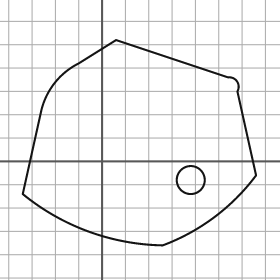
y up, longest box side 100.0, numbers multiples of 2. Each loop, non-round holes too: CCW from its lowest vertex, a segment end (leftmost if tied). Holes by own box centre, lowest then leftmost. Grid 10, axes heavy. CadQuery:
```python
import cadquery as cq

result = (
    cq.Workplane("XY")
    .moveTo(26.0, -36.0)
    .threePointArc((48.0, -24.0), (66.0, -6.0))
    .lineTo(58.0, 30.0)
    .threePointArc((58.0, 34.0), (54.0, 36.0))
    .lineTo(6.0, 52.0)
    .lineTo(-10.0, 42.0)
    .threePointArc((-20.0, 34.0), (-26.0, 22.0))
    .lineTo(-34.0, -14.0)
    .threePointArc((-6.0, -30.0), (26.0, -36.0))
    .close()
    .moveTo(38.0, -8.0)
    .circle(6.0)
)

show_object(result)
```